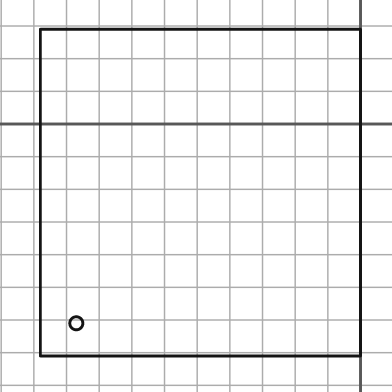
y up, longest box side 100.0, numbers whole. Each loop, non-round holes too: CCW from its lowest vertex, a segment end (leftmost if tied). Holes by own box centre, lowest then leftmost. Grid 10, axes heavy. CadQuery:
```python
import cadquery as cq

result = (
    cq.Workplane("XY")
    .moveTo(-98.0, -71.0)
    .lineTo(0.0, -71.0)
    .lineTo(0.0, 29.0)
    .lineTo(-98.0, 29.0)
    .close()
    .moveTo(-87.0, -61.0)
    .circle(2.0)
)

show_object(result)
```